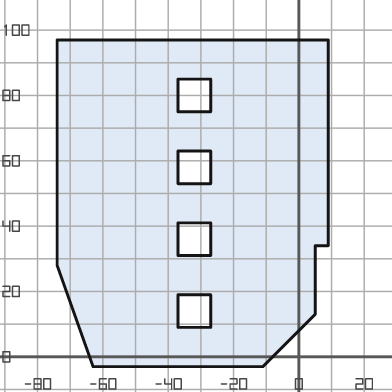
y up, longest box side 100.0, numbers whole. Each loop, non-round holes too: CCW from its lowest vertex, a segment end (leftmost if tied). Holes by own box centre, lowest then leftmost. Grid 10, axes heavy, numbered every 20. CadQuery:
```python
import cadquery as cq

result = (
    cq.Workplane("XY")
    .moveTo(-63.0, -3.0)
    .lineTo(-11.0, -3.0)
    .lineTo(5.0, 13.0)
    .lineTo(5.0, 34.0)
    .lineTo(9.0, 34.0)
    .lineTo(9.0, 97.0)
    .lineTo(-74.0, 97.0)
    .lineTo(-74.0, 28.0)
    .close()
    .moveTo(-37.0, 9.0)
    .lineTo(-27.0, 9.0)
    .lineTo(-27.0, 19.0)
    .lineTo(-37.0, 19.0)
    .close()
    .moveTo(-37.0, 31.0)
    .lineTo(-27.0, 31.0)
    .lineTo(-27.0, 41.0)
    .lineTo(-37.0, 41.0)
    .close()
    .moveTo(-37.0, 53.0)
    .lineTo(-27.0, 53.0)
    .lineTo(-27.0, 63.0)
    .lineTo(-37.0, 63.0)
    .close()
    .moveTo(-37.0, 75.0)
    .lineTo(-27.0, 75.0)
    .lineTo(-27.0, 85.0)
    .lineTo(-37.0, 85.0)
    .close()
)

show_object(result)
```